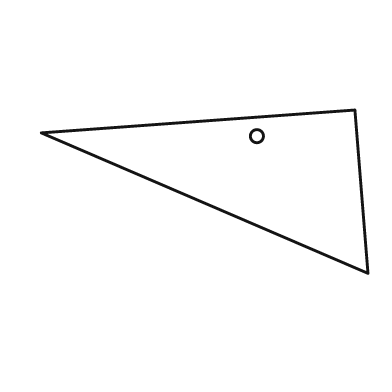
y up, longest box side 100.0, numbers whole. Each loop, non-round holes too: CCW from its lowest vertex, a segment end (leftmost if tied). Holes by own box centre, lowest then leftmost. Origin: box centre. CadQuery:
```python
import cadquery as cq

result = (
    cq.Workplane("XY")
    .moveTo(50.0, -25.0)
    .lineTo(46.0, 25.0)
    .lineTo(-50.0, 18.0)
    .close()
    .moveTo(16.0, 17.0)
    .circle(2.0)
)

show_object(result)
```